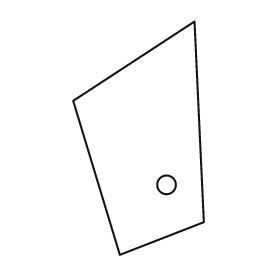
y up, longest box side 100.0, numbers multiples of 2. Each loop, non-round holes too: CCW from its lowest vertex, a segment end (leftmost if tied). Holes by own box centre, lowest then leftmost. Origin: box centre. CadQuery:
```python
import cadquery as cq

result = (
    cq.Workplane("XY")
    .moveTo(-8.0, -50.0)
    .lineTo(28.0, -36.0)
    .lineTo(24.0, 50.0)
    .lineTo(-28.0, 16.0)
    .close()
    .moveTo(12.0, -20.0)
    .circle(4.0)
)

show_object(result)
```